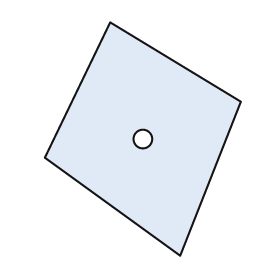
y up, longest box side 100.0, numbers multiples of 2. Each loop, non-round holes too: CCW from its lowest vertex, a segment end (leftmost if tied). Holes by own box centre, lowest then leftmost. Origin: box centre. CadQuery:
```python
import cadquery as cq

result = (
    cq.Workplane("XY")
    .moveTo(16.0, -50.0)
    .lineTo(42.0, 16.0)
    .lineTo(-14.0, 50.0)
    .lineTo(-42.0, -8.0)
    .close()
    .moveTo(0.0, 0.0)
    .circle(4.0)
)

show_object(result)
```